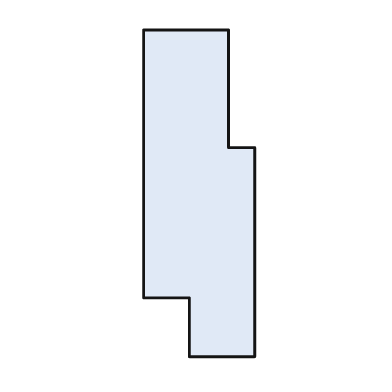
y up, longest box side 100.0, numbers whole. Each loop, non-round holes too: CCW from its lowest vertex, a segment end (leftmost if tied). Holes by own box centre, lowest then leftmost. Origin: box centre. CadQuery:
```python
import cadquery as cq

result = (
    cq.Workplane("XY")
    .moveTo(-3.0, -50.0)
    .lineTo(17.0, -50.0)
    .lineTo(17.0, 14.0)
    .lineTo(9.0, 14.0)
    .lineTo(9.0, 50.0)
    .lineTo(-17.0, 50.0)
    .lineTo(-17.0, -32.0)
    .lineTo(-3.0, -32.0)
    .close()
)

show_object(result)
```